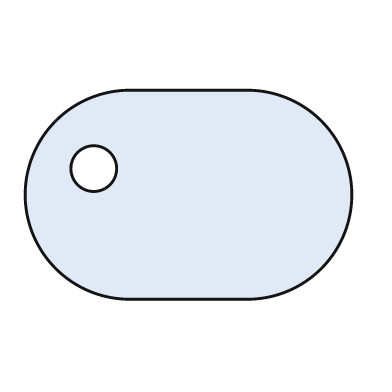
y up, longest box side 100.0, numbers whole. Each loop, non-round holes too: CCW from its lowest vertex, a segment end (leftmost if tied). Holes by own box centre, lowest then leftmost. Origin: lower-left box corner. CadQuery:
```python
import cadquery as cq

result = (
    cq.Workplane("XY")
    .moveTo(32.0, 0.0)
    .lineTo(68.0, 0.0)
    .threePointArc((100.0, 32.0), (68.0, 64.0))
    .lineTo(32.0, 64.0)
    .threePointArc((0.0, 32.0), (32.0, 0.0))
    .close()
    .moveTo(21.0, 40.0)
    .circle(7.0)
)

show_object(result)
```